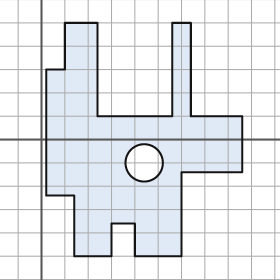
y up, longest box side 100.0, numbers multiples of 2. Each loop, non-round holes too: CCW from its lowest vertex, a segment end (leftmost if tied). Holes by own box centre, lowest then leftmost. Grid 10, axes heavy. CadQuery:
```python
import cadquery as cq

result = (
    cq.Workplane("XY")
    .moveTo(14.0, -50.0)
    .lineTo(30.0, -50.0)
    .lineTo(30.0, -36.0)
    .lineTo(40.0, -36.0)
    .lineTo(40.0, -50.0)
    .lineTo(60.0, -50.0)
    .lineTo(60.0, -14.0)
    .lineTo(86.0, -14.0)
    .lineTo(86.0, 10.0)
    .lineTo(64.0, 10.0)
    .lineTo(64.0, 50.0)
    .lineTo(56.0, 50.0)
    .lineTo(56.0, 10.0)
    .lineTo(24.0, 10.0)
    .lineTo(24.0, 50.0)
    .lineTo(10.0, 50.0)
    .lineTo(10.0, 30.0)
    .lineTo(2.0, 30.0)
    .lineTo(2.0, -24.0)
    .lineTo(14.0, -24.0)
    .close()
    .moveTo(44.0, -10.0)
    .circle(8.0)
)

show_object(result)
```